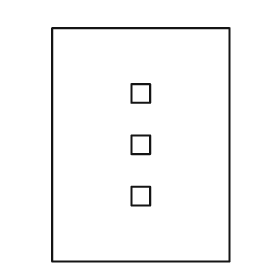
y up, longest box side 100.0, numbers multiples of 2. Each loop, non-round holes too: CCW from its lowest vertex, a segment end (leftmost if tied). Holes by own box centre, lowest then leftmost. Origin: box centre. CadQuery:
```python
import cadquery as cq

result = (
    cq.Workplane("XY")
    .moveTo(-38.0, -50.0)
    .lineTo(38.0, -50.0)
    .lineTo(38.0, 50.0)
    .lineTo(-38.0, 50.0)
    .close()
    .moveTo(-4.0, -26.0)
    .lineTo(4.0, -26.0)
    .lineTo(4.0, -18.0)
    .lineTo(-4.0, -18.0)
    .close()
    .moveTo(-4.0, -4.0)
    .lineTo(4.0, -4.0)
    .lineTo(4.0, 4.0)
    .lineTo(-4.0, 4.0)
    .close()
    .moveTo(-4.0, 18.0)
    .lineTo(4.0, 18.0)
    .lineTo(4.0, 26.0)
    .lineTo(-4.0, 26.0)
    .close()
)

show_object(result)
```